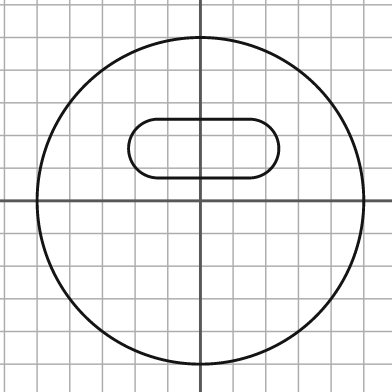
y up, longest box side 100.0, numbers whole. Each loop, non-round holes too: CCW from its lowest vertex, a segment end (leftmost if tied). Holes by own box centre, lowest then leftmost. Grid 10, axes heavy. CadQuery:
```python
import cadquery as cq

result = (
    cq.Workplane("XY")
    .moveTo(0.0, 0.0)
    .circle(50.0)
    .moveTo(-13.0, 7.0)
    .lineTo(15.0, 7.0)
    .threePointArc((24.0, 16.0), (15.0, 25.0))
    .lineTo(-13.0, 25.0)
    .threePointArc((-22.0, 16.0), (-13.0, 7.0))
    .close()
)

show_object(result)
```